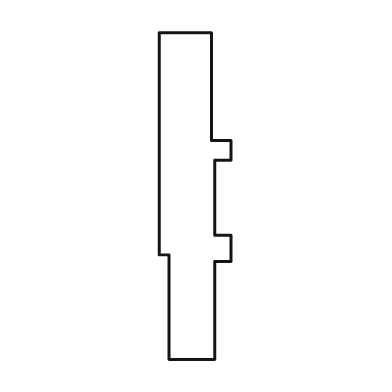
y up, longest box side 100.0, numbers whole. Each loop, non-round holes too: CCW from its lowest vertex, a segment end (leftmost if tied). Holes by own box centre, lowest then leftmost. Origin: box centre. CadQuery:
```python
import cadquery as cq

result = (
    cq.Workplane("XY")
    .moveTo(-8.0, -50.0)
    .lineTo(6.0, -50.0)
    .lineTo(6.0, -20.0)
    .lineTo(11.0, -20.0)
    .lineTo(11.0, -12.0)
    .lineTo(6.0, -12.0)
    .lineTo(6.0, 11.0)
    .lineTo(11.0, 11.0)
    .lineTo(11.0, 17.0)
    .lineTo(5.0, 17.0)
    .lineTo(5.0, 50.0)
    .lineTo(-11.0, 50.0)
    .lineTo(-11.0, -18.0)
    .lineTo(-8.0, -18.0)
    .close()
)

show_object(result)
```